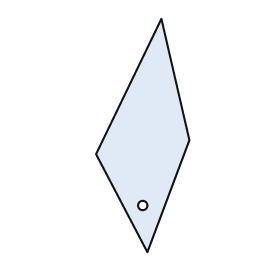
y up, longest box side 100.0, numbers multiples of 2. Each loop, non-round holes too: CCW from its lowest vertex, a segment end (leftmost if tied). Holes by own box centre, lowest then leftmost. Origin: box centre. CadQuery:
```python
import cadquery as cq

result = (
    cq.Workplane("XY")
    .moveTo(2.0, -50.0)
    .lineTo(20.0, -2.0)
    .lineTo(8.0, 50.0)
    .lineTo(-20.0, -8.0)
    .close()
    .moveTo(0.0, -30.0)
    .circle(2.0)
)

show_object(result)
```